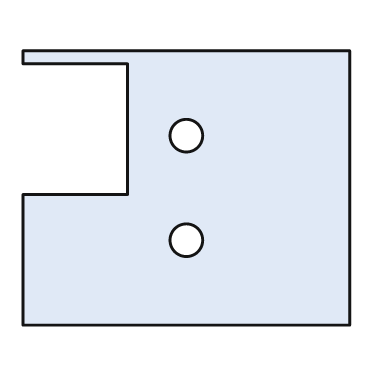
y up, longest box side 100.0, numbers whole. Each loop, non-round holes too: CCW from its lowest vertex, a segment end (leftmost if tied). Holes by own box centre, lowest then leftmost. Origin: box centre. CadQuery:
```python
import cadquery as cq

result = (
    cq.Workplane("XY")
    .moveTo(-50.0, -42.0)
    .lineTo(50.0, -42.0)
    .lineTo(50.0, 42.0)
    .lineTo(-50.0, 42.0)
    .lineTo(-50.0, 38.0)
    .lineTo(-18.0, 38.0)
    .lineTo(-18.0, -2.0)
    .lineTo(-50.0, -2.0)
    .close()
    .moveTo(0.0, -16.0)
    .circle(5.0)
    .moveTo(0.0, 16.0)
    .circle(5.0)
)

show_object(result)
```